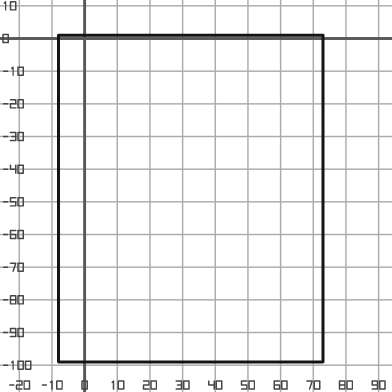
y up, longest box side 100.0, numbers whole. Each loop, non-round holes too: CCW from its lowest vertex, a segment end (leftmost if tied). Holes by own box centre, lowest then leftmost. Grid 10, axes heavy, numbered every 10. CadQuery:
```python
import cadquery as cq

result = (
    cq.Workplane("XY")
    .moveTo(-8.0, -99.0)
    .lineTo(73.0, -99.0)
    .lineTo(73.0, 1.0)
    .lineTo(-8.0, 1.0)
    .close()
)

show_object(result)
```